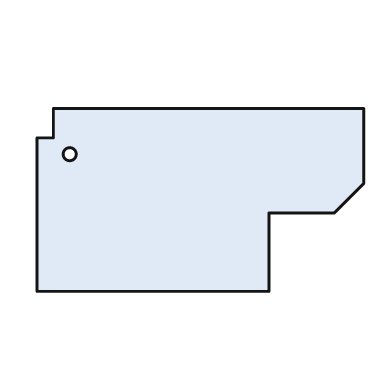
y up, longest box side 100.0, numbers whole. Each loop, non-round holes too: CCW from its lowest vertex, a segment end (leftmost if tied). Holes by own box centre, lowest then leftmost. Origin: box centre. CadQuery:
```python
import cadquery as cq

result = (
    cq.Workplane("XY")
    .moveTo(-50.0, -28.0)
    .lineTo(21.0, -28.0)
    .lineTo(21.0, -4.0)
    .lineTo(41.0, -4.0)
    .lineTo(50.0, 5.0)
    .lineTo(50.0, 28.0)
    .lineTo(-45.0, 28.0)
    .lineTo(-45.0, 19.0)
    .lineTo(-50.0, 19.0)
    .close()
    .moveTo(-40.0, 14.0)
    .circle(2.0)
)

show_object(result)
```